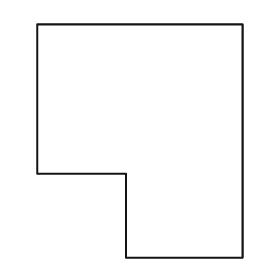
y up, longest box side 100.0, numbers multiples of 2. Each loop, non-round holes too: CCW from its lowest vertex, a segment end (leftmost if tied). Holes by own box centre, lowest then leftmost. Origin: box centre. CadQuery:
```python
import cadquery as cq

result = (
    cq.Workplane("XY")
    .moveTo(-6.0, -50.0)
    .lineTo(44.0, -50.0)
    .lineTo(44.0, 50.0)
    .lineTo(-44.0, 50.0)
    .lineTo(-44.0, -14.0)
    .lineTo(-6.0, -14.0)
    .close()
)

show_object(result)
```